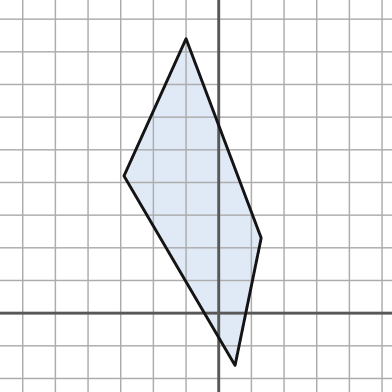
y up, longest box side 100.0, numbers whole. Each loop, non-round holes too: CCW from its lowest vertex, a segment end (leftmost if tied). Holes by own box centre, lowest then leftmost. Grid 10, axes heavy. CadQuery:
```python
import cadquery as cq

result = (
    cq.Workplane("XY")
    .moveTo(5.0, -16.0)
    .lineTo(13.0, 23.0)
    .lineTo(-10.0, 84.0)
    .lineTo(-29.0, 42.0)
    .close()
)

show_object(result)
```